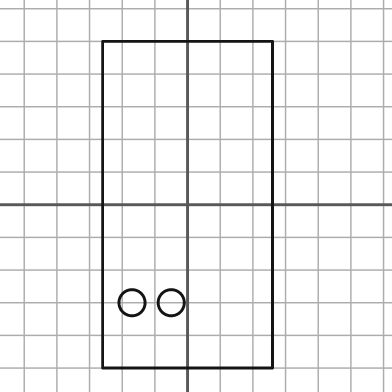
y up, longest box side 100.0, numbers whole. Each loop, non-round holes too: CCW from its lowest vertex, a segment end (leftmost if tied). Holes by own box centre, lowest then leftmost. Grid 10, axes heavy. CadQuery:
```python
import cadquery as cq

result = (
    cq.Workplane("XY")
    .moveTo(-26.0, -50.0)
    .lineTo(26.0, -50.0)
    .lineTo(26.0, 50.0)
    .lineTo(-26.0, 50.0)
    .close()
    .moveTo(-17.0, -30.0)
    .circle(4.0)
    .moveTo(-5.0, -30.0)
    .circle(4.0)
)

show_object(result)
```